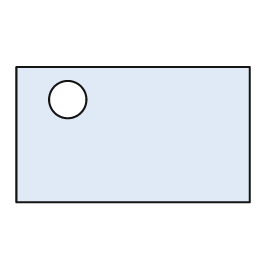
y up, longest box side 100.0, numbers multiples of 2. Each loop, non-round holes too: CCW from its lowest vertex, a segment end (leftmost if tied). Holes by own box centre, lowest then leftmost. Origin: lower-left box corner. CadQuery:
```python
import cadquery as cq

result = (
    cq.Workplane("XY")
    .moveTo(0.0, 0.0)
    .lineTo(100.0, 0.0)
    .lineTo(100.0, 58.0)
    .lineTo(0.0, 58.0)
    .close()
    .moveTo(22.0, 44.0)
    .circle(8.0)
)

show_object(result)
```